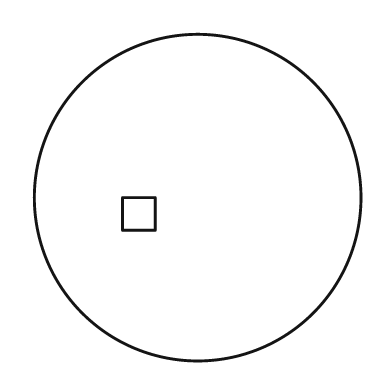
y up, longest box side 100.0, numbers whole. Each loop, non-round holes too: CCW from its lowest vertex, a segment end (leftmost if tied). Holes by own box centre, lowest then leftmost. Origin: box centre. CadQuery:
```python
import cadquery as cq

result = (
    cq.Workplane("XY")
    .moveTo(0.0, 0.0)
    .circle(50.0)
    .moveTo(-23.0, -10.0)
    .lineTo(-13.0, -10.0)
    .lineTo(-13.0, 0.0)
    .lineTo(-23.0, 0.0)
    .close()
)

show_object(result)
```